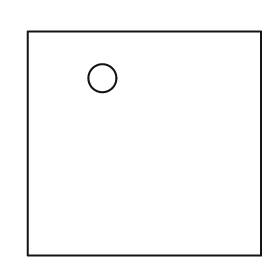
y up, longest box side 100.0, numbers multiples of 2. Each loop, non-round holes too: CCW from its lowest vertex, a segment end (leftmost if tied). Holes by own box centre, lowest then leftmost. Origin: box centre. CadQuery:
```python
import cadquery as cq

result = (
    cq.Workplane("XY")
    .moveTo(-50.0, -48.0)
    .lineTo(50.0, -48.0)
    .lineTo(50.0, 48.0)
    .lineTo(-50.0, 48.0)
    .close()
    .moveTo(-18.0, 28.0)
    .circle(6.0)
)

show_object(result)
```